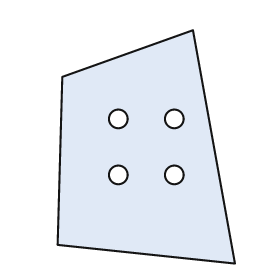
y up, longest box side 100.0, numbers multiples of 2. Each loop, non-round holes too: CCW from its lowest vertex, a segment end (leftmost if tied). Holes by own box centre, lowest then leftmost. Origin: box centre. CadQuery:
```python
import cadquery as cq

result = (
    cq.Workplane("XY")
    .moveTo(38.0, -50.0)
    .lineTo(20.0, 50.0)
    .lineTo(-36.0, 30.0)
    .lineTo(-38.0, -42.0)
    .close()
    .moveTo(-12.0, -12.0)
    .circle(4.0)
    .moveTo(12.0, -12.0)
    .circle(4.0)
    .moveTo(-12.0, 12.0)
    .circle(4.0)
    .moveTo(12.0, 12.0)
    .circle(4.0)
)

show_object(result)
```